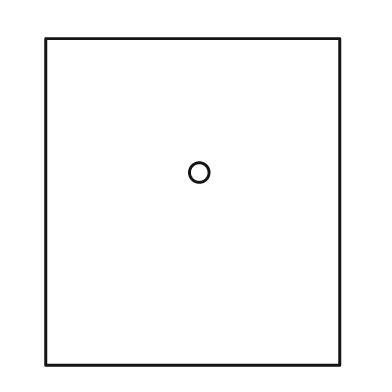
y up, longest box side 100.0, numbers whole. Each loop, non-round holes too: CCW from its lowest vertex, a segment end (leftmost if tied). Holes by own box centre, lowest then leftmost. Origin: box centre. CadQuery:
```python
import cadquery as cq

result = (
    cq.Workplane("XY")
    .moveTo(-45.0, -50.0)
    .lineTo(45.0, -50.0)
    .lineTo(45.0, 50.0)
    .lineTo(-45.0, 50.0)
    .close()
    .moveTo(2.0, 9.0)
    .circle(3.0)
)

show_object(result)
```